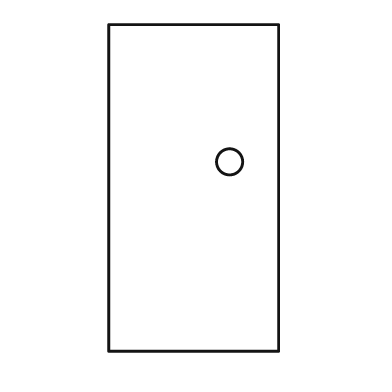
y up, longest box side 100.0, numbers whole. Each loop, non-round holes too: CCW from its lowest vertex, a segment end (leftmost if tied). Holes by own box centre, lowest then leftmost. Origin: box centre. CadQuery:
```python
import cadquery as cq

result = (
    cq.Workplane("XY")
    .moveTo(-26.0, -50.0)
    .lineTo(26.0, -50.0)
    .lineTo(26.0, 50.0)
    .lineTo(-26.0, 50.0)
    .close()
    .moveTo(11.0, 8.0)
    .circle(4.0)
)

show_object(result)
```